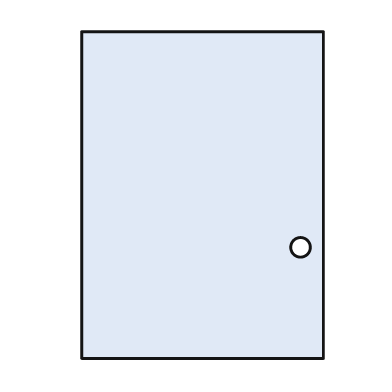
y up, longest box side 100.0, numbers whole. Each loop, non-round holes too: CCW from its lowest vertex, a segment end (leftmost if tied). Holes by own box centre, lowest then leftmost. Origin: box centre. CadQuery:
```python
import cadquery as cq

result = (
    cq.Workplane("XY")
    .moveTo(-37.0, -50.0)
    .lineTo(37.0, -50.0)
    .lineTo(37.0, 50.0)
    .lineTo(-37.0, 50.0)
    .close()
    .moveTo(30.0, -16.0)
    .circle(3.0)
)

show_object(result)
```